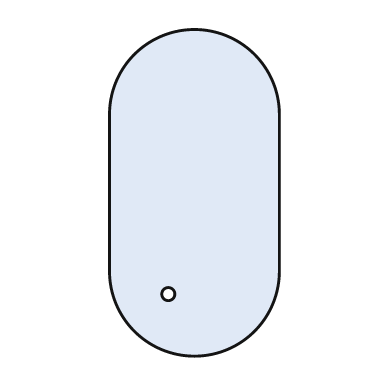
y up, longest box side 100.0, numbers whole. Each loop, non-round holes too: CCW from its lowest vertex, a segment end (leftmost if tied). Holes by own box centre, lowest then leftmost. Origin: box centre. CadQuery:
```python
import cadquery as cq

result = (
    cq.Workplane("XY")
    .moveTo(-26.0, -24.0)
    .threePointArc((0.0, -50.0), (26.0, -24.0))
    .lineTo(26.0, 24.0)
    .threePointArc((0.0, 50.0), (-26.0, 24.0))
    .close()
    .moveTo(-8.0, -31.0)
    .circle(2.0)
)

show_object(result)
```